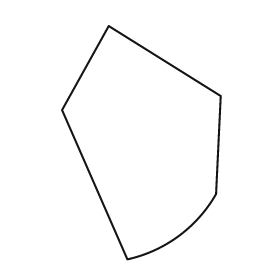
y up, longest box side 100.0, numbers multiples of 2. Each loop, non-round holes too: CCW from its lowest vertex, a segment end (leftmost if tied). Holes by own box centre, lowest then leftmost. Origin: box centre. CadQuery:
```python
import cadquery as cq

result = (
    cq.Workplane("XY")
    .moveTo(-6.0, -50.0)
    .threePointArc((16.0, -40.0), (32.0, -22.0))
    .lineTo(34.0, 20.0)
    .lineTo(-14.0, 50.0)
    .lineTo(-34.0, 14.0)
    .close()
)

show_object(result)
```